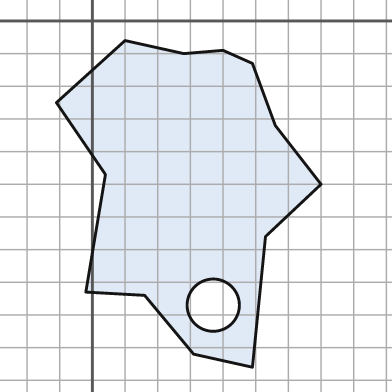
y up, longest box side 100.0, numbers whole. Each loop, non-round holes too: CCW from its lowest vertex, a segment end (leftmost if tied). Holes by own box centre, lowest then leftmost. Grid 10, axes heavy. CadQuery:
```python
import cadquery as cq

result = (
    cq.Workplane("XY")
    .moveTo(49.0, -106.0)
    .lineTo(53.0, -66.0)
    .lineTo(70.0, -50.0)
    .lineTo(56.0, -32.0)
    .lineTo(49.0, -13.0)
    .lineTo(40.0, -9.0)
    .lineTo(28.0, -10.0)
    .lineTo(10.0, -6.0)
    .lineTo(-11.0, -25.0)
    .lineTo(4.0, -47.0)
    .lineTo(-2.0, -83.0)
    .lineTo(16.0, -84.0)
    .lineTo(31.0, -102.0)
    .close()
    .moveTo(37.0, -87.0)
    .circle(8.0)
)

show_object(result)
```